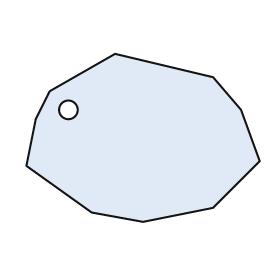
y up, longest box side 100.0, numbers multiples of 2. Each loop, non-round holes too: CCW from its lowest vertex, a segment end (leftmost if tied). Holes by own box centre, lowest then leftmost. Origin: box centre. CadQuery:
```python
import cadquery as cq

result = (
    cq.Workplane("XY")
    .moveTo(0.0, -36.0)
    .lineTo(30.0, -30.0)
    .lineTo(50.0, -10.0)
    .lineTo(42.0, 12.0)
    .lineTo(30.0, 26.0)
    .lineTo(-12.0, 36.0)
    .lineTo(-40.0, 20.0)
    .lineTo(-46.0, 8.0)
    .lineTo(-50.0, -12.0)
    .lineTo(-22.0, -32.0)
    .close()
    .moveTo(-32.0, 12.0)
    .circle(4.0)
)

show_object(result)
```